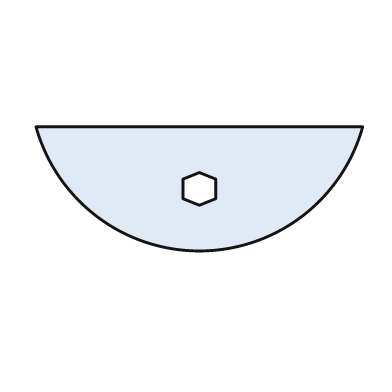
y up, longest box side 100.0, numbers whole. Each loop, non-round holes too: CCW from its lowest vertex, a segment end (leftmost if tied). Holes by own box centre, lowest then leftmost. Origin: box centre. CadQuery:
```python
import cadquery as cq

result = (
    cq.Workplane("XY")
    .moveTo(-50.0, 19.0)
    .threePointArc((0.0, -19.0), (50.0, 19.0))
    .close()
    .moveTo(0.0, -5.0)
    .lineTo(5.0, -3.0)
    .lineTo(5.0, 3.0)
    .lineTo(0.0, 5.0)
    .lineTo(-5.0, 3.0)
    .lineTo(-5.0, -3.0)
    .close()
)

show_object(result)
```